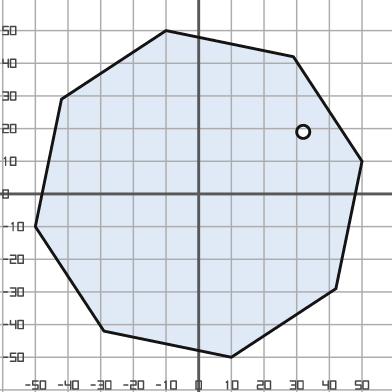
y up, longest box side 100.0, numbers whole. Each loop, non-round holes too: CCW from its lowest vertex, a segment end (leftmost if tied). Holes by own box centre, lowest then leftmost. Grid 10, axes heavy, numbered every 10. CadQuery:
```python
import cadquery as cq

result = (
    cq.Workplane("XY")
    .moveTo(10.0, -50.0)
    .lineTo(42.0, -29.0)
    .lineTo(50.0, 10.0)
    .lineTo(29.0, 42.0)
    .lineTo(-10.0, 50.0)
    .lineTo(-42.0, 29.0)
    .lineTo(-50.0, -10.0)
    .lineTo(-29.0, -42.0)
    .close()
    .moveTo(32.0, 19.0)
    .circle(2.0)
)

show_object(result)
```